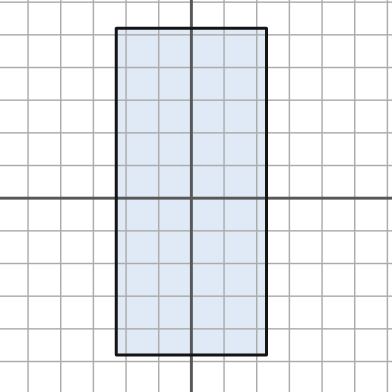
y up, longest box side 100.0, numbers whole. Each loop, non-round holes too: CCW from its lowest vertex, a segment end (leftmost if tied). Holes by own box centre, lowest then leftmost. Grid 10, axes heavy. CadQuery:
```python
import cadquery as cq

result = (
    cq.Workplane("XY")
    .moveTo(-23.0, -48.0)
    .lineTo(23.0, -48.0)
    .lineTo(23.0, 52.0)
    .lineTo(-23.0, 52.0)
    .close()
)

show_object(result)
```